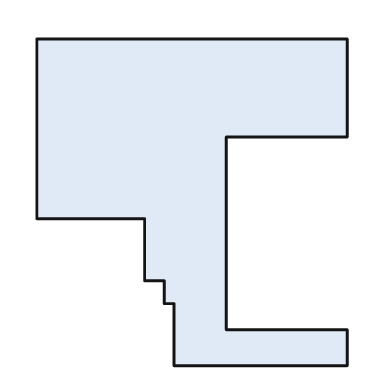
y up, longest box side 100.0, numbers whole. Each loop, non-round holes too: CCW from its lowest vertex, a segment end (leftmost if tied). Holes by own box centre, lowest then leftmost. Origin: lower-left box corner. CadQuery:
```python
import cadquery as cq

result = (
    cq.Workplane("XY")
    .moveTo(42.0, 0.0)
    .lineTo(95.0, 0.0)
    .lineTo(95.0, 11.0)
    .lineTo(58.0, 11.0)
    .lineTo(58.0, 70.0)
    .lineTo(95.0, 70.0)
    .lineTo(95.0, 100.0)
    .lineTo(0.0, 100.0)
    .lineTo(0.0, 45.0)
    .lineTo(33.0, 45.0)
    .lineTo(33.0, 26.0)
    .lineTo(39.0, 26.0)
    .lineTo(39.0, 19.0)
    .lineTo(42.0, 19.0)
    .close()
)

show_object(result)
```